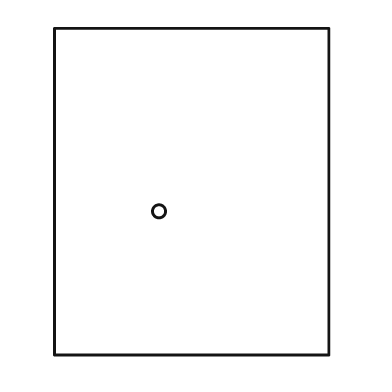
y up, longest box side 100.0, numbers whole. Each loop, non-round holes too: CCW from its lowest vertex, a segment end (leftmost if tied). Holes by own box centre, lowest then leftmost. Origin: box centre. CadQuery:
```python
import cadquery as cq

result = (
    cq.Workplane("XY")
    .moveTo(-42.0, -50.0)
    .lineTo(42.0, -50.0)
    .lineTo(42.0, 50.0)
    .lineTo(-42.0, 50.0)
    .close()
    .moveTo(-10.0, -6.0)
    .circle(2.0)
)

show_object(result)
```